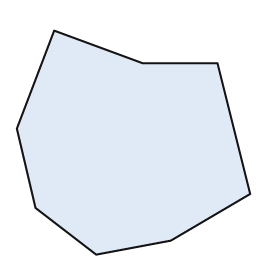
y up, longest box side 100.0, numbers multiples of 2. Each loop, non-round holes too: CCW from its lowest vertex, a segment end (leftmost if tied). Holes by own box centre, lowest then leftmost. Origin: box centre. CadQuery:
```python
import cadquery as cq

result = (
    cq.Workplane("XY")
    .moveTo(-16.0, -48.0)
    .lineTo(16.0, -42.0)
    .lineTo(50.0, -22.0)
    .lineTo(36.0, 34.0)
    .lineTo(4.0, 34.0)
    .lineTo(-34.0, 48.0)
    .lineTo(-50.0, 6.0)
    .lineTo(-42.0, -28.0)
    .close()
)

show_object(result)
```